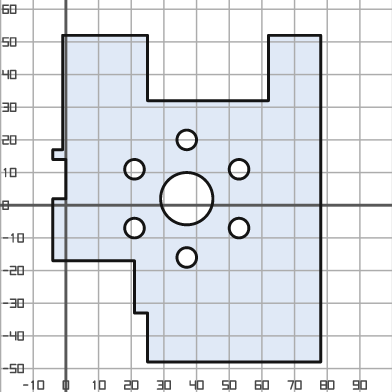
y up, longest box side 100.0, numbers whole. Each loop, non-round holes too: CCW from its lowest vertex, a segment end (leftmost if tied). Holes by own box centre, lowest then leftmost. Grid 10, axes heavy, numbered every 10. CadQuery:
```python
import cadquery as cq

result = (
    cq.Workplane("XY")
    .moveTo(25.0, -48.0)
    .lineTo(78.0, -48.0)
    .lineTo(78.0, 52.0)
    .lineTo(62.0, 52.0)
    .lineTo(62.0, 32.0)
    .lineTo(25.0, 32.0)
    .lineTo(25.0, 52.0)
    .lineTo(-1.0, 52.0)
    .lineTo(-1.0, 17.0)
    .lineTo(-4.0, 17.0)
    .lineTo(-4.0, 14.0)
    .lineTo(0.0, 14.0)
    .lineTo(0.0, 2.0)
    .lineTo(-4.0, 2.0)
    .lineTo(-4.0, -17.0)
    .lineTo(21.0, -17.0)
    .lineTo(21.0, -33.0)
    .lineTo(25.0, -33.0)
    .close()
    .moveTo(37.0, -16.0)
    .circle(3.0)
    .moveTo(21.0, -7.0)
    .circle(3.0)
    .moveTo(53.0, -7.0)
    .circle(3.0)
    .moveTo(37.0, 2.0)
    .circle(8.0)
    .moveTo(21.0, 11.0)
    .circle(3.0)
    .moveTo(53.0, 11.0)
    .circle(3.0)
    .moveTo(37.0, 20.0)
    .circle(3.0)
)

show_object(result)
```